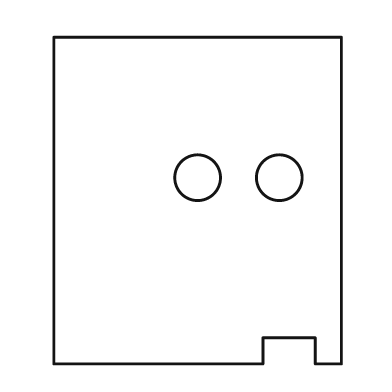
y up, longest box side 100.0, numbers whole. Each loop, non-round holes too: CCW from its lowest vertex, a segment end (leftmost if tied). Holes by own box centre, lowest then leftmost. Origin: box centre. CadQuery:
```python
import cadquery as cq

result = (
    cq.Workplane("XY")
    .moveTo(-44.0, -50.0)
    .lineTo(20.0, -50.0)
    .lineTo(20.0, -42.0)
    .lineTo(36.0, -42.0)
    .lineTo(36.0, -50.0)
    .lineTo(44.0, -50.0)
    .lineTo(44.0, 50.0)
    .lineTo(-44.0, 50.0)
    .close()
    .moveTo(0.0, 7.0)
    .circle(7.0)
    .moveTo(25.0, 7.0)
    .circle(7.0)
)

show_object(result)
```